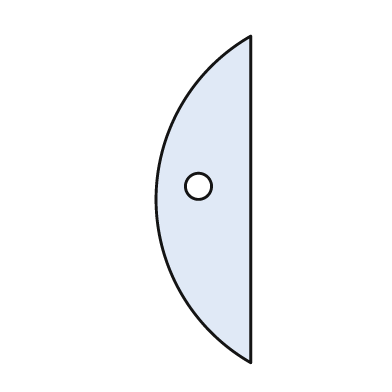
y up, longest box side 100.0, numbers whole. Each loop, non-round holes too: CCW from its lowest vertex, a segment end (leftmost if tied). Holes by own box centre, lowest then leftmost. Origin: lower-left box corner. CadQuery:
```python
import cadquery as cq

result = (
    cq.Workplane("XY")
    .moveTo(29.0, 0.0)
    .lineTo(29.0, 100.0)
    .threePointArc((0.0, 50.0), (29.0, 0.0))
    .close()
    .moveTo(13.0, 54.0)
    .circle(4.0)
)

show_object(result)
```